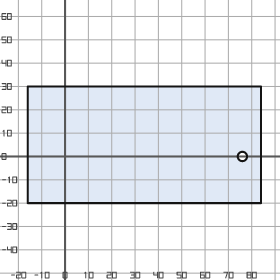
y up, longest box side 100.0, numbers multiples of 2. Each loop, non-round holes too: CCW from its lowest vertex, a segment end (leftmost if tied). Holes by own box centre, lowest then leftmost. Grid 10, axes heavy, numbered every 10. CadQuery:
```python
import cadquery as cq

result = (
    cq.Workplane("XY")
    .moveTo(-16.0, -20.0)
    .lineTo(84.0, -20.0)
    .lineTo(84.0, 30.0)
    .lineTo(-16.0, 30.0)
    .close()
    .moveTo(76.0, 0.0)
    .circle(2.0)
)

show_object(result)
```